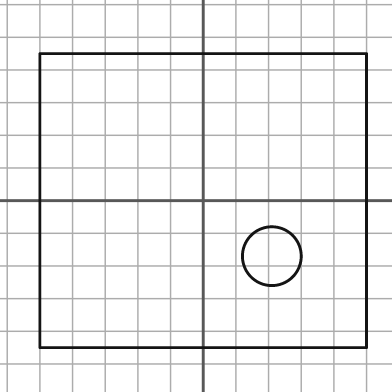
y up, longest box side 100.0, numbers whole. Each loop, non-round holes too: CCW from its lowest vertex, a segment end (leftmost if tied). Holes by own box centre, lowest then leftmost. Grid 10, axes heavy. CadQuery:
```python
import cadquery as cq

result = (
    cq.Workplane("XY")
    .moveTo(-50.0, -45.0)
    .lineTo(50.0, -45.0)
    .lineTo(50.0, 45.0)
    .lineTo(-50.0, 45.0)
    .close()
    .moveTo(21.0, -17.0)
    .circle(9.0)
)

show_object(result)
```